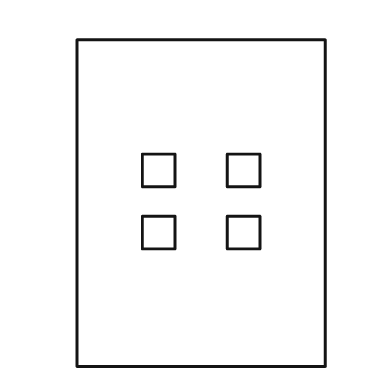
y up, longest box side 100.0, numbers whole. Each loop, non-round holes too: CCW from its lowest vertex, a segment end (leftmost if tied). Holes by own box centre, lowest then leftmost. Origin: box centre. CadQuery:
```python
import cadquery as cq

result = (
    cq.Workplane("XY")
    .moveTo(-38.0, -50.0)
    .lineTo(38.0, -50.0)
    .lineTo(38.0, 50.0)
    .lineTo(-38.0, 50.0)
    .close()
    .moveTo(-18.0, -14.0)
    .lineTo(-8.0, -14.0)
    .lineTo(-8.0, -4.0)
    .lineTo(-18.0, -4.0)
    .close()
    .moveTo(8.0, -14.0)
    .lineTo(18.0, -14.0)
    .lineTo(18.0, -4.0)
    .lineTo(8.0, -4.0)
    .close()
    .moveTo(-18.0, 5.0)
    .lineTo(-8.0, 5.0)
    .lineTo(-8.0, 15.0)
    .lineTo(-18.0, 15.0)
    .close()
    .moveTo(8.0, 5.0)
    .lineTo(18.0, 5.0)
    .lineTo(18.0, 15.0)
    .lineTo(8.0, 15.0)
    .close()
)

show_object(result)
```